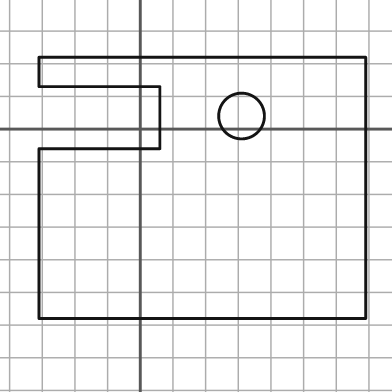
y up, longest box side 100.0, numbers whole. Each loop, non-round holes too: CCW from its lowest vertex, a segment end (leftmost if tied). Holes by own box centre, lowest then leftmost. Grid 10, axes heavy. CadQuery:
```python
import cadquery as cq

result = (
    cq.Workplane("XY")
    .moveTo(-31.0, -58.0)
    .lineTo(69.0, -58.0)
    .lineTo(69.0, 22.0)
    .lineTo(-31.0, 22.0)
    .lineTo(-31.0, 13.0)
    .lineTo(6.0, 13.0)
    .lineTo(6.0, -6.0)
    .lineTo(-31.0, -6.0)
    .close()
    .moveTo(31.0, 4.0)
    .circle(7.0)
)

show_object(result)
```